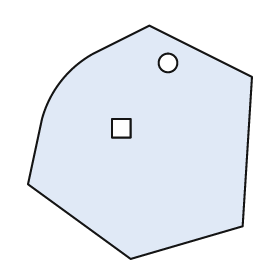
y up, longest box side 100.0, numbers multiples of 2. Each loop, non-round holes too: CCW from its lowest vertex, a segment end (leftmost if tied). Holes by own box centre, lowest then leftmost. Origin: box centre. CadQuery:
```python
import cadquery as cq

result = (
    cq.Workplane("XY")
    .moveTo(-4.0, -50.0)
    .lineTo(44.0, -36.0)
    .lineTo(48.0, 28.0)
    .lineTo(4.0, 50.0)
    .lineTo(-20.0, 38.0)
    .threePointArc((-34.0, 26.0), (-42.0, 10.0))
    .lineTo(-48.0, -18.0)
    .close()
    .moveTo(-12.0, 2.0)
    .lineTo(-4.0, 2.0)
    .lineTo(-4.0, 10.0)
    .lineTo(-12.0, 10.0)
    .close()
    .moveTo(12.0, 34.0)
    .circle(4.0)
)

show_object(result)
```